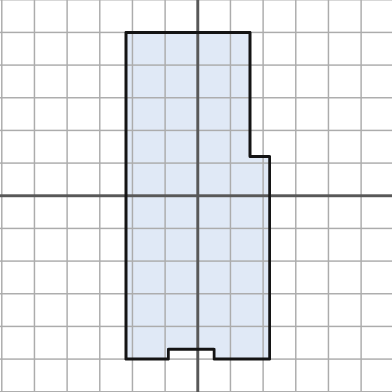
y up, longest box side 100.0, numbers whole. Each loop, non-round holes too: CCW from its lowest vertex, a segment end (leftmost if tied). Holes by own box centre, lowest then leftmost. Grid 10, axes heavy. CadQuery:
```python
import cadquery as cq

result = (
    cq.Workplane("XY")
    .moveTo(-22.0, -50.0)
    .lineTo(-9.0, -50.0)
    .lineTo(-9.0, -47.0)
    .lineTo(5.0, -47.0)
    .lineTo(5.0, -50.0)
    .lineTo(22.0, -50.0)
    .lineTo(22.0, 12.0)
    .lineTo(16.0, 12.0)
    .lineTo(16.0, 50.0)
    .lineTo(-22.0, 50.0)
    .close()
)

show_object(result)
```